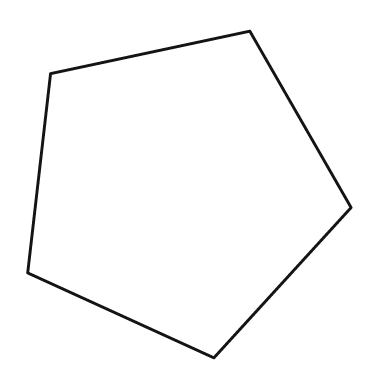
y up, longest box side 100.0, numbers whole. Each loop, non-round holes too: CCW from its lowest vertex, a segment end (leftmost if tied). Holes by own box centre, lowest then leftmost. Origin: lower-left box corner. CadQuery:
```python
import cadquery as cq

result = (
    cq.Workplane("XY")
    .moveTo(57.0, 0.0)
    .lineTo(99.0, 46.0)
    .lineTo(68.0, 100.0)
    .lineTo(7.0, 87.0)
    .lineTo(0.0, 26.0)
    .close()
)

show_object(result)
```